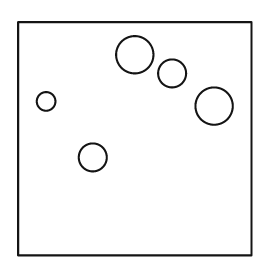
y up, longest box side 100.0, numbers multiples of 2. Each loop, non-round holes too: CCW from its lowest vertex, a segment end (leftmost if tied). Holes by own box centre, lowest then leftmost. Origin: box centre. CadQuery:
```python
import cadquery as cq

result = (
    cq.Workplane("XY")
    .moveTo(-50.0, -50.0)
    .lineTo(50.0, -50.0)
    .lineTo(50.0, 50.0)
    .lineTo(-50.0, 50.0)
    .close()
    .moveTo(-18.0, -8.0)
    .circle(6.0)
    .moveTo(34.0, 14.0)
    .circle(8.0)
    .moveTo(-38.0, 16.0)
    .circle(4.0)
    .moveTo(16.0, 28.0)
    .circle(6.0)
    .moveTo(0.0, 36.0)
    .circle(8.0)
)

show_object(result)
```